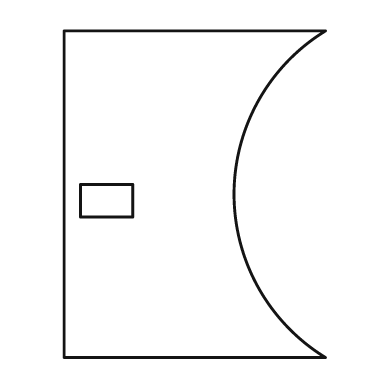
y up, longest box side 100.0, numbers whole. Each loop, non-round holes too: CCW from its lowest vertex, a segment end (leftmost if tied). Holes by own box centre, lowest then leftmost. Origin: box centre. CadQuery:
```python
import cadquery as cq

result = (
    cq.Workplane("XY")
    .moveTo(-40.0, -50.0)
    .lineTo(40.0, -50.0)
    .threePointArc((12.0, 0.0), (40.0, 50.0))
    .lineTo(-40.0, 50.0)
    .close()
    .moveTo(-35.0, -7.0)
    .lineTo(-19.0, -7.0)
    .lineTo(-19.0, 3.0)
    .lineTo(-35.0, 3.0)
    .close()
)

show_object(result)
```